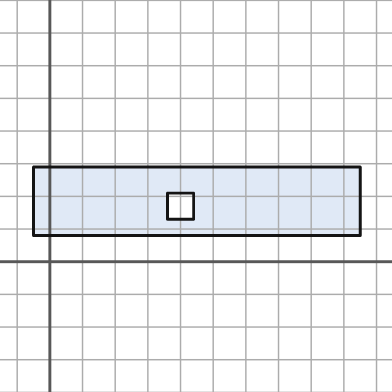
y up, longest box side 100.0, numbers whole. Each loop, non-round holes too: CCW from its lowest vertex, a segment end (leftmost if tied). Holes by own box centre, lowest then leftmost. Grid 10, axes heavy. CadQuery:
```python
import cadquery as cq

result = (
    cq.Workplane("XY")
    .moveTo(-5.0, 8.0)
    .lineTo(95.0, 8.0)
    .lineTo(95.0, 29.0)
    .lineTo(-5.0, 29.0)
    .close()
    .moveTo(36.0, 13.0)
    .lineTo(44.0, 13.0)
    .lineTo(44.0, 21.0)
    .lineTo(36.0, 21.0)
    .close()
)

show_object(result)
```